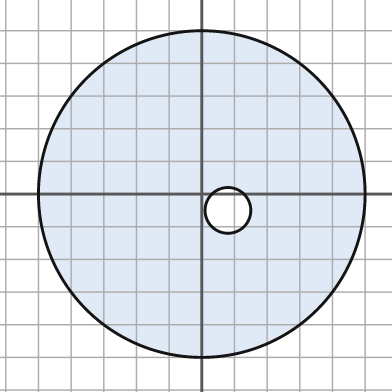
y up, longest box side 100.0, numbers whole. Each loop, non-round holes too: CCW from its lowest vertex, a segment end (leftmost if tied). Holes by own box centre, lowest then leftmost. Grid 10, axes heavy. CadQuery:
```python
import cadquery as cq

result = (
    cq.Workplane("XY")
    .moveTo(0.0, 0.0)
    .circle(50.0)
    .moveTo(8.0, -5.0)
    .circle(7.0)
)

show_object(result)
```